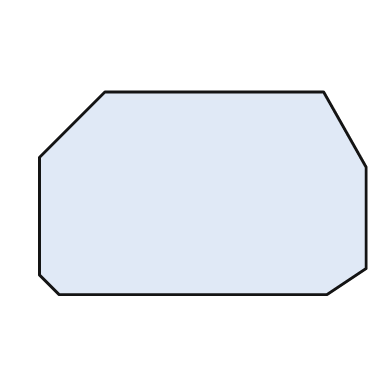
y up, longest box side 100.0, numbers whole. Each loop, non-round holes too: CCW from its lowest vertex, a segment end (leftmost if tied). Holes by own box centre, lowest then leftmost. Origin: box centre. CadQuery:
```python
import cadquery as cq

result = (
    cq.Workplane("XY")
    .moveTo(-44.0, -31.0)
    .lineTo(38.0, -31.0)
    .lineTo(50.0, -23.0)
    .lineTo(50.0, 8.0)
    .lineTo(37.0, 31.0)
    .lineTo(-30.0, 31.0)
    .lineTo(-50.0, 11.0)
    .lineTo(-50.0, -25.0)
    .close()
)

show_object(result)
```